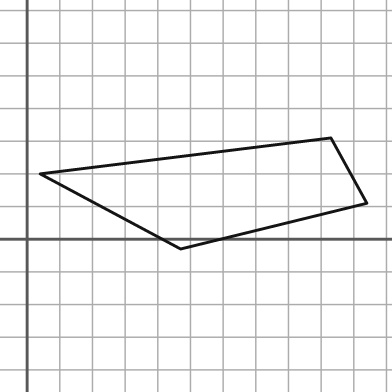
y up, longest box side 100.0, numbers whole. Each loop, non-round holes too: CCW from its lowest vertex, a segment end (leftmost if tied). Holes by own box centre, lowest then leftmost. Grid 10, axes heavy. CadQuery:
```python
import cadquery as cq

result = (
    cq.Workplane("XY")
    .moveTo(47.0, -3.0)
    .lineTo(104.0, 11.0)
    .lineTo(93.0, 31.0)
    .lineTo(4.0, 20.0)
    .close()
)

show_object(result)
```